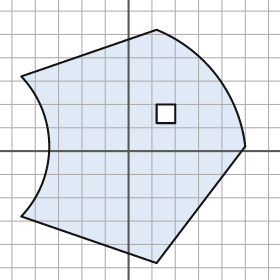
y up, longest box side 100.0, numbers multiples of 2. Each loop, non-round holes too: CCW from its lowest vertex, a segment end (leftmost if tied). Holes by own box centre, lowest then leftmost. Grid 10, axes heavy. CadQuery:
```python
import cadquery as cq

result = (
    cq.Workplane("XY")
    .moveTo(12.0, -48.0)
    .lineTo(50.0, 2.0)
    .threePointArc((38.0, 32.0), (12.0, 52.0))
    .lineTo(-46.0, 32.0)
    .threePointArc((-34.0, 2.0), (-46.0, -28.0))
    .close()
    .moveTo(12.0, 12.0)
    .lineTo(20.0, 12.0)
    .lineTo(20.0, 20.0)
    .lineTo(12.0, 20.0)
    .close()
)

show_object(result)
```